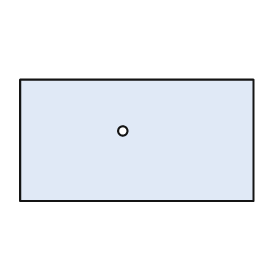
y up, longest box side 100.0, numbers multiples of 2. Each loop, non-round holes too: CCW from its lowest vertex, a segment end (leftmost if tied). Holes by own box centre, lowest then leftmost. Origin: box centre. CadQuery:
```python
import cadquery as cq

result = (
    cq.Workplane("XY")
    .moveTo(-50.0, -26.0)
    .lineTo(50.0, -26.0)
    .lineTo(50.0, 26.0)
    .lineTo(-50.0, 26.0)
    .close()
    .moveTo(-6.0, 4.0)
    .circle(2.0)
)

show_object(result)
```